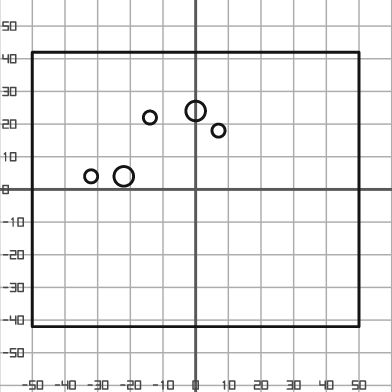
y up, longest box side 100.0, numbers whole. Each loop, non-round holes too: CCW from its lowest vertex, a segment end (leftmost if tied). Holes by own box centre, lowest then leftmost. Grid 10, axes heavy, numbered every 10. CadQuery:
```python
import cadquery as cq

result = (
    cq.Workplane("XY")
    .moveTo(-50.0, -42.0)
    .lineTo(50.0, -42.0)
    .lineTo(50.0, 42.0)
    .lineTo(-50.0, 42.0)
    .close()
    .moveTo(-32.0, 4.0)
    .circle(2.0)
    .moveTo(-22.0, 4.0)
    .circle(3.0)
    .moveTo(7.0, 18.0)
    .circle(2.0)
    .moveTo(-14.0, 22.0)
    .circle(2.0)
    .moveTo(0.0, 24.0)
    .circle(3.0)
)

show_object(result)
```